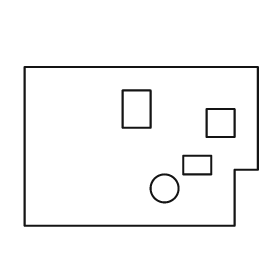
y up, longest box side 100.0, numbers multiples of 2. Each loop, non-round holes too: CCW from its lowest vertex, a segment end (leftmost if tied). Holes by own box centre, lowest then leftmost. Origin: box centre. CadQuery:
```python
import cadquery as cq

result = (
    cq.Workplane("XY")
    .moveTo(-50.0, -34.0)
    .lineTo(40.0, -34.0)
    .lineTo(40.0, -10.0)
    .lineTo(50.0, -10.0)
    .lineTo(50.0, 34.0)
    .lineTo(-50.0, 34.0)
    .close()
    .moveTo(10.0, -18.0)
    .circle(6.0)
    .moveTo(18.0, -12.0)
    .lineTo(30.0, -12.0)
    .lineTo(30.0, -4.0)
    .lineTo(18.0, -4.0)
    .close()
    .moveTo(28.0, 4.0)
    .lineTo(40.0, 4.0)
    .lineTo(40.0, 16.0)
    .lineTo(28.0, 16.0)
    .close()
    .moveTo(-8.0, 8.0)
    .lineTo(4.0, 8.0)
    .lineTo(4.0, 24.0)
    .lineTo(-8.0, 24.0)
    .close()
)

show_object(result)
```